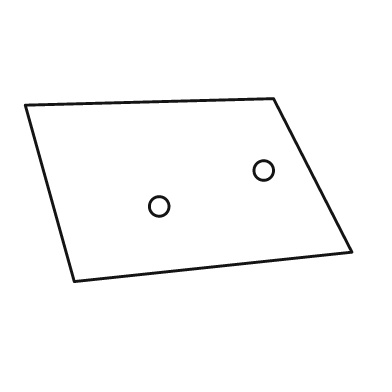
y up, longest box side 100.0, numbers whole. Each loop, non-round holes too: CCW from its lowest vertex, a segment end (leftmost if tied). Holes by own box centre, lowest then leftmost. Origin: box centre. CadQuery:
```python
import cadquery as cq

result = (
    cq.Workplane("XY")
    .moveTo(-35.0, -28.0)
    .lineTo(50.0, -19.0)
    .lineTo(26.0, 28.0)
    .lineTo(-50.0, 26.0)
    .close()
    .moveTo(-9.0, -5.0)
    .circle(3.0)
    .moveTo(23.0, 6.0)
    .circle(3.0)
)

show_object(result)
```